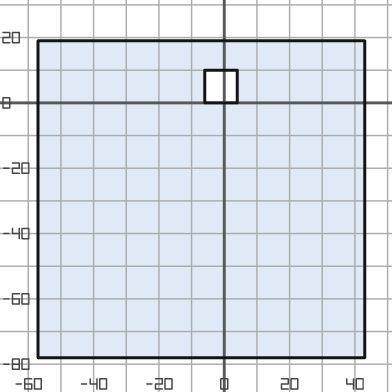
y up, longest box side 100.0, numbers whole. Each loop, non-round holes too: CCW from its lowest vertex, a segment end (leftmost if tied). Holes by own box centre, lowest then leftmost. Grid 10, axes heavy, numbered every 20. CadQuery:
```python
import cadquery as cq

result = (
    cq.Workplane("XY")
    .moveTo(-57.0, -78.0)
    .lineTo(43.0, -78.0)
    .lineTo(43.0, 19.0)
    .lineTo(-57.0, 19.0)
    .close()
    .moveTo(-6.0, 0.0)
    .lineTo(4.0, 0.0)
    .lineTo(4.0, 10.0)
    .lineTo(-6.0, 10.0)
    .close()
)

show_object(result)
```